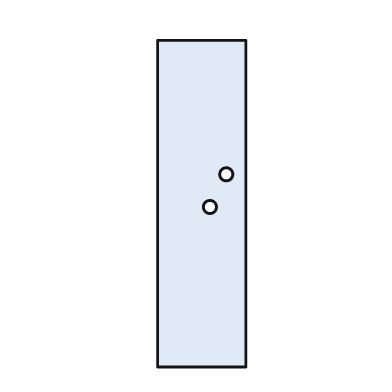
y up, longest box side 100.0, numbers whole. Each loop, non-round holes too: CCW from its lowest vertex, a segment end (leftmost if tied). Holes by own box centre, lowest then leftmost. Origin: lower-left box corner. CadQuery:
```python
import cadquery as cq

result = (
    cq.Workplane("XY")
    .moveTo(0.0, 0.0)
    .lineTo(27.0, 0.0)
    .lineTo(27.0, 100.0)
    .lineTo(0.0, 100.0)
    .close()
    .moveTo(16.0, 49.0)
    .circle(2.0)
    .moveTo(21.0, 59.0)
    .circle(2.0)
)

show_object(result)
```